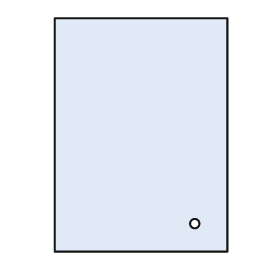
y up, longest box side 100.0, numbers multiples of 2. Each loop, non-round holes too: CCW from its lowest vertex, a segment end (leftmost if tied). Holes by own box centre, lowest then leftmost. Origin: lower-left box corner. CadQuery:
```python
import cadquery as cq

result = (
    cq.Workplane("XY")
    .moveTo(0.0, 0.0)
    .lineTo(74.0, 0.0)
    .lineTo(74.0, 100.0)
    .lineTo(0.0, 100.0)
    .close()
    .moveTo(60.0, 12.0)
    .circle(2.0)
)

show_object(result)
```